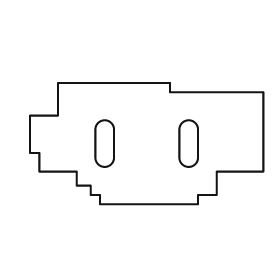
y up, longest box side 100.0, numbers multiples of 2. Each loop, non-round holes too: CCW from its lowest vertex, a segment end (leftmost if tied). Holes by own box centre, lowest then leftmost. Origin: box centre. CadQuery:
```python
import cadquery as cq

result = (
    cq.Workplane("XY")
    .moveTo(-20.0, -26.0)
    .lineTo(22.0, -26.0)
    .lineTo(22.0, -22.0)
    .lineTo(30.0, -22.0)
    .lineTo(30.0, -12.0)
    .lineTo(50.0, -12.0)
    .lineTo(50.0, 22.0)
    .lineTo(10.0, 22.0)
    .lineTo(10.0, 26.0)
    .lineTo(-38.0, 26.0)
    .lineTo(-38.0, 12.0)
    .lineTo(-50.0, 12.0)
    .lineTo(-50.0, -4.0)
    .lineTo(-46.0, -4.0)
    .lineTo(-46.0, -12.0)
    .lineTo(-30.0, -12.0)
    .lineTo(-30.0, -18.0)
    .lineTo(-24.0, -18.0)
    .lineTo(-24.0, -22.0)
    .lineTo(-20.0, -22.0)
    .close()
    .moveTo(-22.0, -6.0)
    .threePointArc((-18.0, -10.0), (-14.0, -6.0))
    .lineTo(-14.0, 6.0)
    .threePointArc((-18.0, 10.0), (-22.0, 6.0))
    .close()
    .moveTo(14.0, -6.0)
    .threePointArc((18.0, -10.0), (22.0, -6.0))
    .lineTo(22.0, 6.0)
    .threePointArc((18.0, 10.0), (14.0, 6.0))
    .close()
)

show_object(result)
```